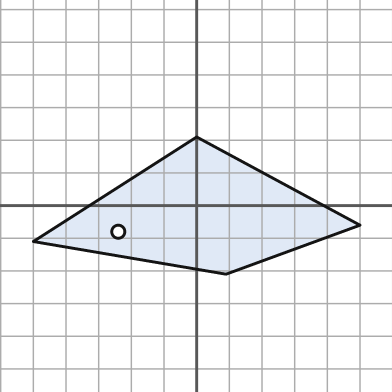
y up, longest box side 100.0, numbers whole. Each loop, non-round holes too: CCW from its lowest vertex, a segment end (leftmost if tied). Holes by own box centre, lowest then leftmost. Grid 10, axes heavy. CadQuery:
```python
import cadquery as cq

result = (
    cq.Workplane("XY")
    .moveTo(9.0, -21.0)
    .lineTo(50.0, -6.0)
    .lineTo(0.0, 21.0)
    .lineTo(-50.0, -11.0)
    .close()
    .moveTo(-24.0, -8.0)
    .circle(2.0)
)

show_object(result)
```